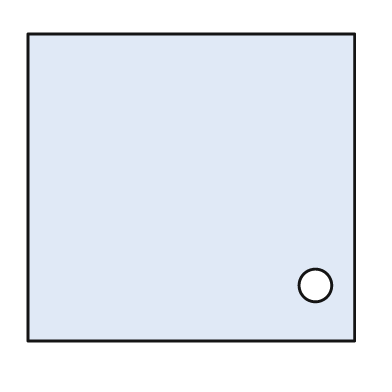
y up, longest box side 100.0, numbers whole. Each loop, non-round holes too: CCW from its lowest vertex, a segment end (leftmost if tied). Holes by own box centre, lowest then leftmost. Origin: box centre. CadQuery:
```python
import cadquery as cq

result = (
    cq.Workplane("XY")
    .moveTo(-50.0, -47.0)
    .lineTo(50.0, -47.0)
    .lineTo(50.0, 47.0)
    .lineTo(-50.0, 47.0)
    .close()
    .moveTo(38.0, -30.0)
    .circle(5.0)
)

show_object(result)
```